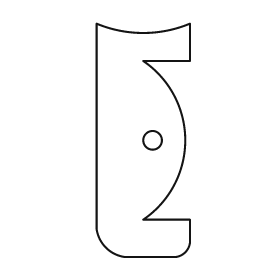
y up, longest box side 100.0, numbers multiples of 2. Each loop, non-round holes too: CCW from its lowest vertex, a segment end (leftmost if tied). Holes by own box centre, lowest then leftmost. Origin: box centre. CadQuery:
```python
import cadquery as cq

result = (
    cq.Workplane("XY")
    .moveTo(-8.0, -50.0)
    .lineTo(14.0, -50.0)
    .threePointArc((18.0, -48.0), (20.0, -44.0))
    .lineTo(20.0, -34.0)
    .lineTo(0.0, -34.0)
    .threePointArc((18.0, 0.0), (0.0, 34.0))
    .lineTo(20.0, 34.0)
    .lineTo(20.0, 50.0)
    .threePointArc((0.0, 46.0), (-20.0, 50.0))
    .lineTo(-20.0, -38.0)
    .threePointArc((-16.0, -46.0), (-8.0, -50.0))
    .close()
    .moveTo(4.0, 0.0)
    .circle(4.0)
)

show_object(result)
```